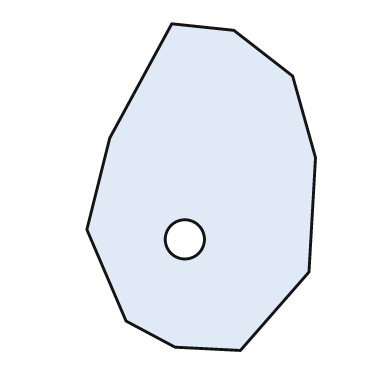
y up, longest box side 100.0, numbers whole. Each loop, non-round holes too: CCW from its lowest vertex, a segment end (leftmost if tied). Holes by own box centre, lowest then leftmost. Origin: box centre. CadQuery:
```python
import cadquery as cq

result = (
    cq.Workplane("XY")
    .moveTo(12.0, -50.0)
    .lineTo(33.0, -26.0)
    .lineTo(35.0, 9.0)
    .lineTo(28.0, 34.0)
    .lineTo(10.0, 48.0)
    .lineTo(-9.0, 50.0)
    .lineTo(-28.0, 15.0)
    .lineTo(-35.0, -13.0)
    .lineTo(-23.0, -41.0)
    .lineTo(-8.0, -49.0)
    .close()
    .moveTo(-5.0, -16.0)
    .circle(6.0)
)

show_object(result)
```